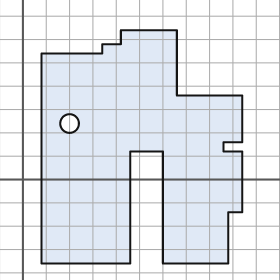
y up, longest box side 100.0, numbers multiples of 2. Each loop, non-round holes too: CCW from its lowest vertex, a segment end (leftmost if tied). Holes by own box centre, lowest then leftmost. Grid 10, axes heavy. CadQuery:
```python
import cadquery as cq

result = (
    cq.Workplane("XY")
    .moveTo(8.0, -36.0)
    .lineTo(46.0, -36.0)
    .lineTo(46.0, 12.0)
    .lineTo(60.0, 12.0)
    .lineTo(60.0, -36.0)
    .lineTo(88.0, -36.0)
    .lineTo(88.0, -14.0)
    .lineTo(94.0, -14.0)
    .lineTo(94.0, 12.0)
    .lineTo(86.0, 12.0)
    .lineTo(86.0, 16.0)
    .lineTo(94.0, 16.0)
    .lineTo(94.0, 36.0)
    .lineTo(66.0, 36.0)
    .lineTo(66.0, 64.0)
    .lineTo(42.0, 64.0)
    .lineTo(42.0, 58.0)
    .lineTo(34.0, 58.0)
    .lineTo(34.0, 54.0)
    .lineTo(8.0, 54.0)
    .close()
    .moveTo(20.0, 24.0)
    .circle(4.0)
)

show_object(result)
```